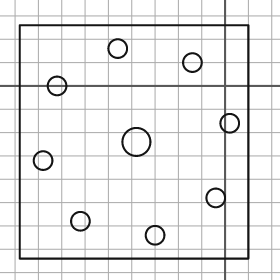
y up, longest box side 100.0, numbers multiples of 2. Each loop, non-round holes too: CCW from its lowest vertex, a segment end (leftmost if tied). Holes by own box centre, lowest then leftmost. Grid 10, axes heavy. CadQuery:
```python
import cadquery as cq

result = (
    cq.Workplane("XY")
    .moveTo(-88.0, -74.0)
    .lineTo(10.0, -74.0)
    .lineTo(10.0, 26.0)
    .lineTo(-88.0, 26.0)
    .close()
    .moveTo(-30.0, -64.0)
    .circle(4.0)
    .moveTo(-62.0, -58.0)
    .circle(4.0)
    .moveTo(-4.0, -48.0)
    .circle(4.0)
    .moveTo(-78.0, -32.0)
    .circle(4.0)
    .moveTo(-38.0, -24.0)
    .circle(6.0)
    .moveTo(2.0, -16.0)
    .circle(4.0)
    .moveTo(-72.0, 0.0)
    .circle(4.0)
    .moveTo(-14.0, 10.0)
    .circle(4.0)
    .moveTo(-46.0, 16.0)
    .circle(4.0)
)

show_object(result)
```